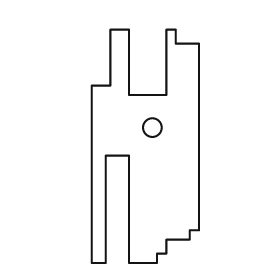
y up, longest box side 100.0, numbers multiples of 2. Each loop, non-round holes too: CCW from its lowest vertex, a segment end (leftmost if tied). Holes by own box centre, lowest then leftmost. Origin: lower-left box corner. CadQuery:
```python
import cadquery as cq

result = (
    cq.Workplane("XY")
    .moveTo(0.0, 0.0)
    .lineTo(6.0, 0.0)
    .lineTo(6.0, 46.0)
    .lineTo(16.0, 46.0)
    .lineTo(16.0, 0.0)
    .lineTo(28.0, 0.0)
    .lineTo(28.0, 4.0)
    .lineTo(32.0, 4.0)
    .lineTo(32.0, 10.0)
    .lineTo(42.0, 10.0)
    .lineTo(42.0, 14.0)
    .lineTo(46.0, 14.0)
    .lineTo(46.0, 94.0)
    .lineTo(36.0, 94.0)
    .lineTo(36.0, 100.0)
    .lineTo(32.0, 100.0)
    .lineTo(32.0, 72.0)
    .lineTo(16.0, 72.0)
    .lineTo(16.0, 100.0)
    .lineTo(8.0, 100.0)
    .lineTo(8.0, 76.0)
    .lineTo(0.0, 76.0)
    .close()
    .moveTo(26.0, 58.0)
    .circle(4.0)
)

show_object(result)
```